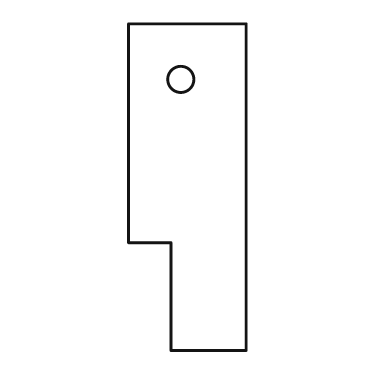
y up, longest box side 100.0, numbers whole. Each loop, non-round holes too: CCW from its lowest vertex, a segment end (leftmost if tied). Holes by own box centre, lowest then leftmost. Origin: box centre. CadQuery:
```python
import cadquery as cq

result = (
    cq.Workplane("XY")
    .moveTo(-5.0, -50.0)
    .lineTo(18.0, -50.0)
    .lineTo(18.0, 50.0)
    .lineTo(-18.0, 50.0)
    .lineTo(-18.0, -17.0)
    .lineTo(-5.0, -17.0)
    .close()
    .moveTo(-2.0, 33.0)
    .circle(4.0)
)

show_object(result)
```